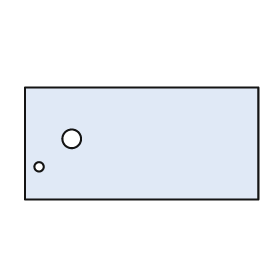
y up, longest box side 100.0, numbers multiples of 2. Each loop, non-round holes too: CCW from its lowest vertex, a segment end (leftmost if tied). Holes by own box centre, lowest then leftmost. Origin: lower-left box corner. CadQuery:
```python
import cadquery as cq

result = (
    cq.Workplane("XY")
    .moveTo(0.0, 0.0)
    .lineTo(100.0, 0.0)
    .lineTo(100.0, 48.0)
    .lineTo(0.0, 48.0)
    .close()
    .moveTo(6.0, 14.0)
    .circle(2.0)
    .moveTo(20.0, 26.0)
    .circle(4.0)
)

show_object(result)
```